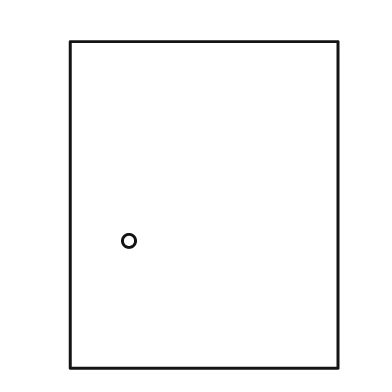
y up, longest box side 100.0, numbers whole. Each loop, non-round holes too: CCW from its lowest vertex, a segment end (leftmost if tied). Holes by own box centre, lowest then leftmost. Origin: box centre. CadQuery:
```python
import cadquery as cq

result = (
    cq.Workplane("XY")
    .moveTo(-41.0, -50.0)
    .lineTo(41.0, -50.0)
    .lineTo(41.0, 50.0)
    .lineTo(-41.0, 50.0)
    .close()
    .moveTo(-23.0, -11.0)
    .circle(2.0)
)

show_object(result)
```